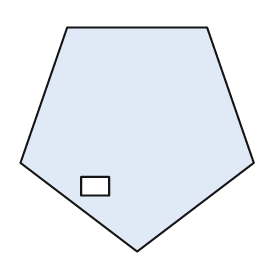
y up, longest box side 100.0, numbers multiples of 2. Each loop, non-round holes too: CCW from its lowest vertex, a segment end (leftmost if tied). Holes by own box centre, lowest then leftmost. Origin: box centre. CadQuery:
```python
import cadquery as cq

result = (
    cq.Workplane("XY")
    .moveTo(0.0, -48.0)
    .lineTo(50.0, -10.0)
    .lineTo(30.0, 48.0)
    .lineTo(-30.0, 48.0)
    .lineTo(-50.0, -10.0)
    .close()
    .moveTo(-24.0, -24.0)
    .lineTo(-12.0, -24.0)
    .lineTo(-12.0, -16.0)
    .lineTo(-24.0, -16.0)
    .close()
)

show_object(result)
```